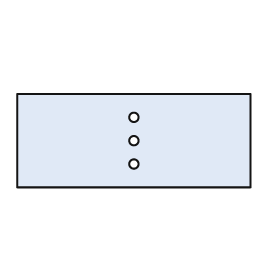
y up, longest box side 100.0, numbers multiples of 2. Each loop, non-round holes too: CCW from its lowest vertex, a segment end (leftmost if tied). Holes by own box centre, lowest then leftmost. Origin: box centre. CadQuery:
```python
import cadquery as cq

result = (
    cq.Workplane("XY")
    .moveTo(-50.0, -20.0)
    .lineTo(50.0, -20.0)
    .lineTo(50.0, 20.0)
    .lineTo(-50.0, 20.0)
    .close()
    .moveTo(0.0, -10.0)
    .circle(2.0)
    .moveTo(0.0, 0.0)
    .circle(2.0)
    .moveTo(0.0, 10.0)
    .circle(2.0)
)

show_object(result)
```